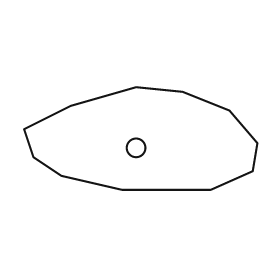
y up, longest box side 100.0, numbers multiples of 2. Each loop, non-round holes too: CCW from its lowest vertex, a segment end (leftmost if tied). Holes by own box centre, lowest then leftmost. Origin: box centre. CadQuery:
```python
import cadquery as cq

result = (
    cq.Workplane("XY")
    .moveTo(-8.0, -22.0)
    .lineTo(30.0, -22.0)
    .lineTo(48.0, -14.0)
    .lineTo(50.0, -2.0)
    .lineTo(38.0, 12.0)
    .lineTo(18.0, 20.0)
    .lineTo(-2.0, 22.0)
    .lineTo(-30.0, 14.0)
    .lineTo(-50.0, 4.0)
    .lineTo(-46.0, -8.0)
    .lineTo(-34.0, -16.0)
    .close()
    .moveTo(-2.0, -4.0)
    .circle(4.0)
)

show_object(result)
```